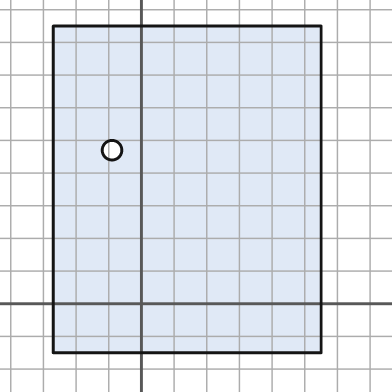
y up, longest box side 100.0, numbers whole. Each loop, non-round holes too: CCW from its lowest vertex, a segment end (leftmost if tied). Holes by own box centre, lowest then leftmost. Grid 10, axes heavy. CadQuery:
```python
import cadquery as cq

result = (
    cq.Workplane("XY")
    .moveTo(-27.0, -15.0)
    .lineTo(55.0, -15.0)
    .lineTo(55.0, 85.0)
    .lineTo(-27.0, 85.0)
    .close()
    .moveTo(-9.0, 47.0)
    .circle(3.0)
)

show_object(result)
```